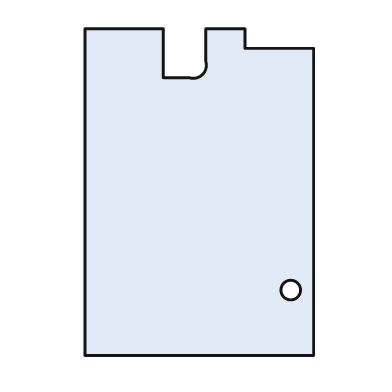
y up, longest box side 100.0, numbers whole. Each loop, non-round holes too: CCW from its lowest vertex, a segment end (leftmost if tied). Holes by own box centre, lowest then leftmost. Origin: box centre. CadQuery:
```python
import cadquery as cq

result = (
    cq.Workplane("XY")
    .moveTo(-35.0, -50.0)
    .lineTo(35.0, -50.0)
    .lineTo(35.0, 44.0)
    .lineTo(14.0, 44.0)
    .lineTo(14.0, 50.0)
    .lineTo(2.0, 50.0)
    .lineTo(2.0, 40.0)
    .threePointArc((1.0, 36.0), (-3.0, 35.0))
    .lineTo(-11.0, 35.0)
    .lineTo(-11.0, 50.0)
    .lineTo(-35.0, 50.0)
    .close()
    .moveTo(28.0, -30.0)
    .circle(3.0)
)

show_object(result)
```